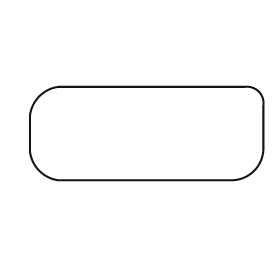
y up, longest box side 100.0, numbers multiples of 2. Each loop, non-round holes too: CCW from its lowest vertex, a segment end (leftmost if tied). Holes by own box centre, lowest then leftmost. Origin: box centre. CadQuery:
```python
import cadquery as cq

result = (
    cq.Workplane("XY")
    .moveTo(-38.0, -20.0)
    .lineTo(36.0, -20.0)
    .threePointArc((46.0, -16.0), (50.0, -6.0))
    .lineTo(50.0, 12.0)
    .threePointArc((48.0, 18.0), (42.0, 20.0))
    .lineTo(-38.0, 20.0)
    .threePointArc((-46.0, 16.0), (-50.0, 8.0))
    .lineTo(-50.0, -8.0)
    .threePointArc((-46.0, -16.0), (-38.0, -20.0))
    .close()
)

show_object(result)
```